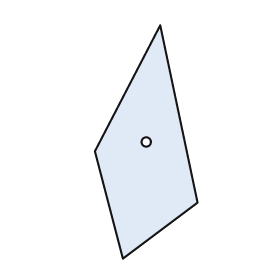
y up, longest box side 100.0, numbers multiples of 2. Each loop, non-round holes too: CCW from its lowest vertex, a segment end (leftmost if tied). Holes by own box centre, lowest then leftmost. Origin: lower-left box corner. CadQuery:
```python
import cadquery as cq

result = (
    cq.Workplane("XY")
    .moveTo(12.0, 0.0)
    .lineTo(44.0, 24.0)
    .lineTo(28.0, 100.0)
    .lineTo(0.0, 46.0)
    .close()
    .moveTo(22.0, 50.0)
    .circle(2.0)
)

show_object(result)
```